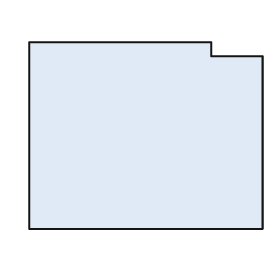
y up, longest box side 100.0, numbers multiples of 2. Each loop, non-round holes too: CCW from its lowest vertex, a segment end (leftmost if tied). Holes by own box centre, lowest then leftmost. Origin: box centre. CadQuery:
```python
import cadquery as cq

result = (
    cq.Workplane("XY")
    .moveTo(-50.0, -40.0)
    .lineTo(50.0, -40.0)
    .lineTo(50.0, 34.0)
    .lineTo(28.0, 34.0)
    .lineTo(28.0, 40.0)
    .lineTo(-50.0, 40.0)
    .close()
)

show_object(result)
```